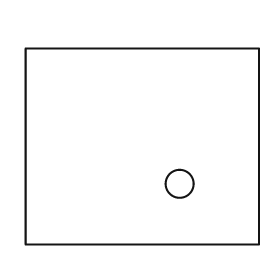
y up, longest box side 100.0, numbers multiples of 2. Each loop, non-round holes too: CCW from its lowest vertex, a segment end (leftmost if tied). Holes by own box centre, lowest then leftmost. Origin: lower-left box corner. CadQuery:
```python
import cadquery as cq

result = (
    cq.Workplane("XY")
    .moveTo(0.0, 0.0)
    .lineTo(100.0, 0.0)
    .lineTo(100.0, 84.0)
    .lineTo(0.0, 84.0)
    .close()
    .moveTo(66.0, 26.0)
    .circle(6.0)
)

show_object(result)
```